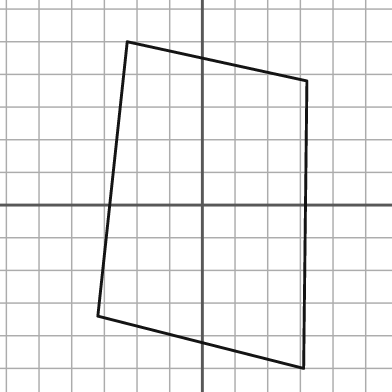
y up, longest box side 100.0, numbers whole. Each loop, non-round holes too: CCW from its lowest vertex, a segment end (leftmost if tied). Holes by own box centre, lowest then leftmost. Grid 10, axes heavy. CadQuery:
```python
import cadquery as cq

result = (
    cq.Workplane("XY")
    .moveTo(31.0, -50.0)
    .lineTo(32.0, 38.0)
    .lineTo(-23.0, 50.0)
    .lineTo(-32.0, -34.0)
    .close()
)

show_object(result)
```